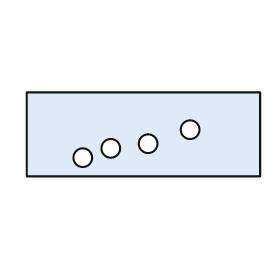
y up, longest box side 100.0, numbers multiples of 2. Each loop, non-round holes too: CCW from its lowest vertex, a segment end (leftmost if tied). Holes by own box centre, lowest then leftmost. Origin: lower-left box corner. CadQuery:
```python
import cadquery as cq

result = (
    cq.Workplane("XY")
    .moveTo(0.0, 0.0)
    .lineTo(100.0, 0.0)
    .lineTo(100.0, 36.0)
    .lineTo(0.0, 36.0)
    .close()
    .moveTo(24.0, 8.0)
    .circle(4.0)
    .moveTo(36.0, 12.0)
    .circle(4.0)
    .moveTo(52.0, 14.0)
    .circle(4.0)
    .moveTo(70.0, 20.0)
    .circle(4.0)
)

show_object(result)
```